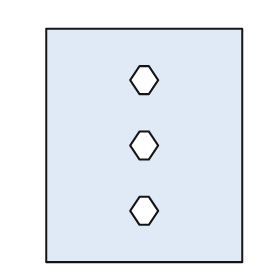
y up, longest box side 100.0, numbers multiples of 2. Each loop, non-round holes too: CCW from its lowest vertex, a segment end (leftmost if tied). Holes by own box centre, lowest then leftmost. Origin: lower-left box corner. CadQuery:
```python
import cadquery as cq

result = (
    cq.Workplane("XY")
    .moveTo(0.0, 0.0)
    .lineTo(84.0, 0.0)
    .lineTo(84.0, 100.0)
    .lineTo(0.0, 100.0)
    .close()
    .moveTo(40.0, 16.0)
    .lineTo(44.0, 16.0)
    .lineTo(48.0, 22.0)
    .lineTo(44.0, 28.0)
    .lineTo(40.0, 28.0)
    .lineTo(36.0, 22.0)
    .close()
    .moveTo(40.0, 44.0)
    .lineTo(44.0, 44.0)
    .lineTo(48.0, 50.0)
    .lineTo(44.0, 56.0)
    .lineTo(40.0, 56.0)
    .lineTo(36.0, 50.0)
    .close()
    .moveTo(40.0, 72.0)
    .lineTo(44.0, 72.0)
    .lineTo(48.0, 78.0)
    .lineTo(44.0, 84.0)
    .lineTo(40.0, 84.0)
    .lineTo(36.0, 78.0)
    .close()
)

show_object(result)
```